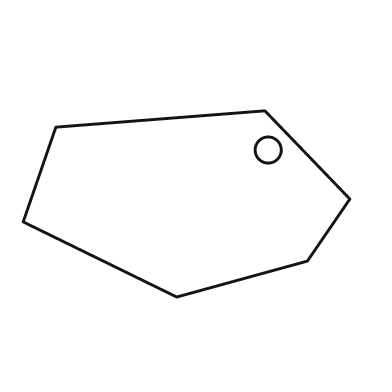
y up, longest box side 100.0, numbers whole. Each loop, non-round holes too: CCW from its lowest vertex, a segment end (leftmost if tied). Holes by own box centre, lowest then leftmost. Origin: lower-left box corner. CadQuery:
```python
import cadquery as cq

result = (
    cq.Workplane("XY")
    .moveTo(47.0, 0.0)
    .lineTo(87.0, 11.0)
    .lineTo(100.0, 30.0)
    .lineTo(74.0, 57.0)
    .lineTo(10.0, 52.0)
    .lineTo(0.0, 23.0)
    .close()
    .moveTo(75.0, 45.0)
    .circle(4.0)
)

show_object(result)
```